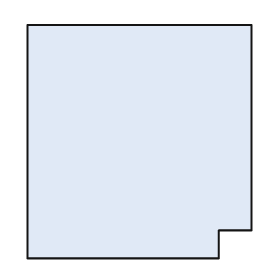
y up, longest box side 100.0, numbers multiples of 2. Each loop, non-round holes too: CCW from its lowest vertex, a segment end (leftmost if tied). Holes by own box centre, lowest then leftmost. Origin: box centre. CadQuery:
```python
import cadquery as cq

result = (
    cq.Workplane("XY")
    .moveTo(-48.0, -50.0)
    .lineTo(34.0, -50.0)
    .lineTo(34.0, -38.0)
    .lineTo(48.0, -38.0)
    .lineTo(48.0, 50.0)
    .lineTo(-48.0, 50.0)
    .close()
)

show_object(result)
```